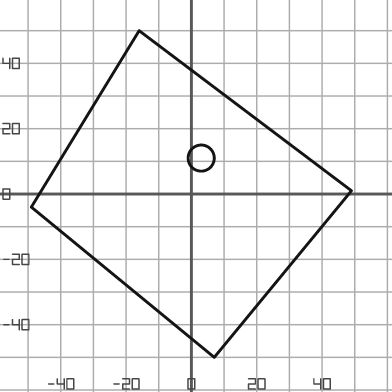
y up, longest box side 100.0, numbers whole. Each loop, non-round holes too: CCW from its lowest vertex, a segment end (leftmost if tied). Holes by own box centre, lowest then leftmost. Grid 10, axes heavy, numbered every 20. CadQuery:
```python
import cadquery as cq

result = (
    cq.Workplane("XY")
    .moveTo(7.0, -50.0)
    .lineTo(49.0, 1.0)
    .lineTo(-16.0, 50.0)
    .lineTo(-49.0, -4.0)
    .close()
    .moveTo(3.0, 11.0)
    .circle(4.0)
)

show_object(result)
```